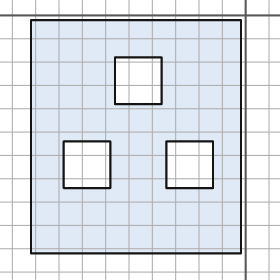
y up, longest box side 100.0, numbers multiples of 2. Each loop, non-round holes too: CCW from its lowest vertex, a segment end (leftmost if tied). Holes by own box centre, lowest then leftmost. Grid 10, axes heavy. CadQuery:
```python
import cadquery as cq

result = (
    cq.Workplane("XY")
    .moveTo(-92.0, -102.0)
    .lineTo(-2.0, -102.0)
    .lineTo(-2.0, -2.0)
    .lineTo(-92.0, -2.0)
    .close()
    .moveTo(-78.0, -74.0)
    .lineTo(-58.0, -74.0)
    .lineTo(-58.0, -54.0)
    .lineTo(-78.0, -54.0)
    .close()
    .moveTo(-34.0, -74.0)
    .lineTo(-14.0, -74.0)
    .lineTo(-14.0, -54.0)
    .lineTo(-34.0, -54.0)
    .close()
    .moveTo(-56.0, -38.0)
    .lineTo(-36.0, -38.0)
    .lineTo(-36.0, -18.0)
    .lineTo(-56.0, -18.0)
    .close()
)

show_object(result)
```